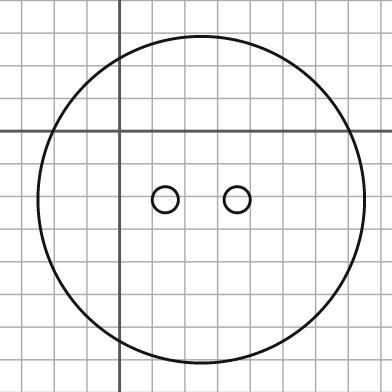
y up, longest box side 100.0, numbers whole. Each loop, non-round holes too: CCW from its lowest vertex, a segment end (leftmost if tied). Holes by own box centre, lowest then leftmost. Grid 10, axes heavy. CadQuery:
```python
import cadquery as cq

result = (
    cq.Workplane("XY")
    .moveTo(25.0, -21.0)
    .circle(50.0)
    .moveTo(14.0, -21.0)
    .circle(4.0)
    .moveTo(36.0, -21.0)
    .circle(4.0)
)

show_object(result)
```